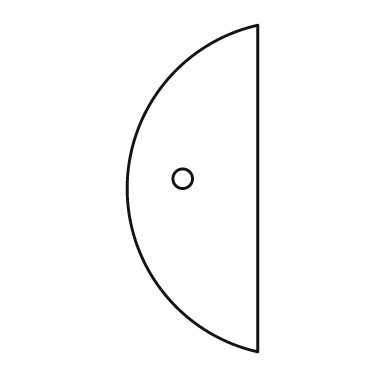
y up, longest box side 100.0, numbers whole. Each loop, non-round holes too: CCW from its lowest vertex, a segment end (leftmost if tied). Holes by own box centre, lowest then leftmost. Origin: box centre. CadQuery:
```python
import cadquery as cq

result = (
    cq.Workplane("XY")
    .moveTo(20.0, -50.0)
    .lineTo(20.0, 50.0)
    .threePointArc((-20.0, 0.0), (20.0, -50.0))
    .close()
    .moveTo(-3.0, 3.0)
    .circle(3.0)
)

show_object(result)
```